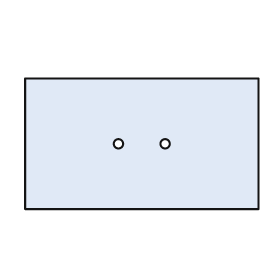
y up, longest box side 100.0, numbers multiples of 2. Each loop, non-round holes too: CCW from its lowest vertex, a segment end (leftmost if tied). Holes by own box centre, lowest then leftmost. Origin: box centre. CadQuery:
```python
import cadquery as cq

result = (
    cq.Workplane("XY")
    .moveTo(-50.0, -28.0)
    .lineTo(50.0, -28.0)
    .lineTo(50.0, 28.0)
    .lineTo(-50.0, 28.0)
    .close()
    .moveTo(-10.0, 0.0)
    .circle(2.0)
    .moveTo(10.0, 0.0)
    .circle(2.0)
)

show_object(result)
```